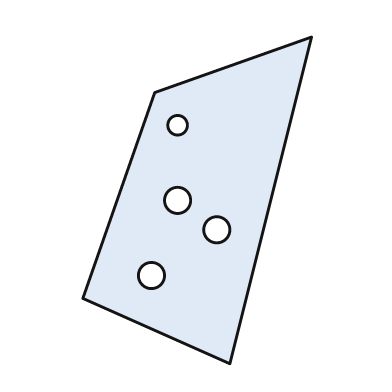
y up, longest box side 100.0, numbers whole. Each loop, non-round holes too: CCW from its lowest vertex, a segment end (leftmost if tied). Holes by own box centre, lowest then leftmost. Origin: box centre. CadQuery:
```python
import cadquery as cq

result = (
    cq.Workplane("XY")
    .moveTo(10.0, -50.0)
    .lineTo(35.0, 50.0)
    .lineTo(-13.0, 33.0)
    .lineTo(-35.0, -30.0)
    .close()
    .moveTo(-14.0, -23.0)
    .circle(4.0)
    .moveTo(6.0, -9.0)
    .circle(4.0)
    .moveTo(-6.0, 0.0)
    .circle(4.0)
    .moveTo(-6.0, 23.0)
    .circle(3.0)
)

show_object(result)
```